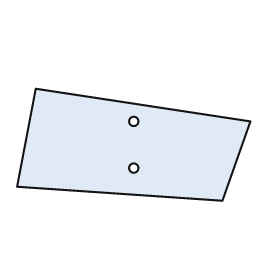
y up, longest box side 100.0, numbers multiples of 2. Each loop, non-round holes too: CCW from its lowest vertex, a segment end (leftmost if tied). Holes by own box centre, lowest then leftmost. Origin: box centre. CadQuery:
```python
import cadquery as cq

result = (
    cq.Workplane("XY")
    .moveTo(38.0, -24.0)
    .lineTo(50.0, 10.0)
    .lineTo(-42.0, 24.0)
    .lineTo(-50.0, -18.0)
    .close()
    .moveTo(0.0, -10.0)
    .circle(2.0)
    .moveTo(0.0, 10.0)
    .circle(2.0)
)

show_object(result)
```